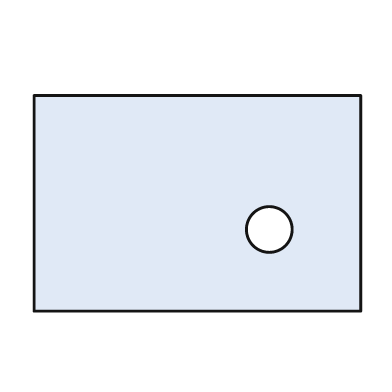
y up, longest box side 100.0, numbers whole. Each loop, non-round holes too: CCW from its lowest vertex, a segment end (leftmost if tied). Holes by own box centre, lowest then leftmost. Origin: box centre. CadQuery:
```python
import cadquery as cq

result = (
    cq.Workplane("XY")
    .moveTo(-50.0, -33.0)
    .lineTo(50.0, -33.0)
    .lineTo(50.0, 33.0)
    .lineTo(-50.0, 33.0)
    .close()
    .moveTo(22.0, -8.0)
    .circle(7.0)
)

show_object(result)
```